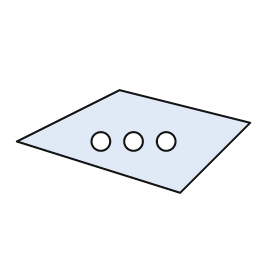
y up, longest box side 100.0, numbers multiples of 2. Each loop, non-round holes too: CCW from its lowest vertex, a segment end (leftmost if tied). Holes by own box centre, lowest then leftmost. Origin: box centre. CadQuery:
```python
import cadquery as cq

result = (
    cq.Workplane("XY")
    .moveTo(20.0, -22.0)
    .lineTo(50.0, 8.0)
    .lineTo(-6.0, 22.0)
    .lineTo(-50.0, 0.0)
    .close()
    .moveTo(-14.0, 0.0)
    .circle(4.0)
    .moveTo(0.0, 0.0)
    .circle(4.0)
    .moveTo(14.0, 0.0)
    .circle(4.0)
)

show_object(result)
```